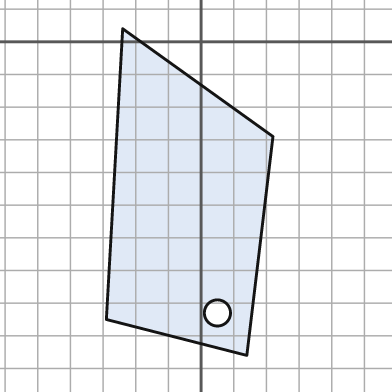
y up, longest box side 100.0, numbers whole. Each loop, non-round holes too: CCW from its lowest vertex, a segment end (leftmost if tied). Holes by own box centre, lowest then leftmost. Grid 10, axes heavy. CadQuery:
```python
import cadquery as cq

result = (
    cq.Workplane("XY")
    .moveTo(14.0, -96.0)
    .lineTo(22.0, -29.0)
    .lineTo(-24.0, 4.0)
    .lineTo(-29.0, -85.0)
    .close()
    .moveTo(5.0, -83.0)
    .circle(4.0)
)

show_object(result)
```